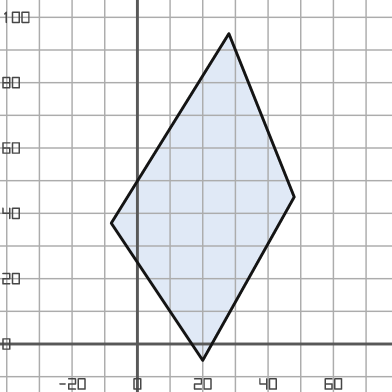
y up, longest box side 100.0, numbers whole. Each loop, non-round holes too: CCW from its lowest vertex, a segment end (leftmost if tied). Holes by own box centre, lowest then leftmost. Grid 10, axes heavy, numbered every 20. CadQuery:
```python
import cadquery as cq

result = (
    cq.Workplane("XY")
    .moveTo(20.0, -5.0)
    .lineTo(48.0, 45.0)
    .lineTo(28.0, 95.0)
    .lineTo(-8.0, 37.0)
    .close()
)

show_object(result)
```